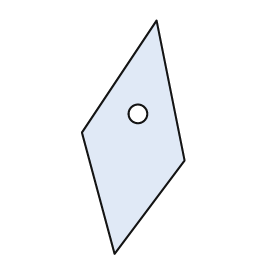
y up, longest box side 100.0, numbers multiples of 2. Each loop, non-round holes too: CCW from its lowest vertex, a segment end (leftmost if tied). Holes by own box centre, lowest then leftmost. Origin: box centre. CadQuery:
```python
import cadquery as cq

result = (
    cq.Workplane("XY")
    .moveTo(-8.0, -50.0)
    .lineTo(22.0, -10.0)
    .lineTo(10.0, 50.0)
    .lineTo(-22.0, 2.0)
    .close()
    .moveTo(2.0, 10.0)
    .circle(4.0)
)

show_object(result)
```